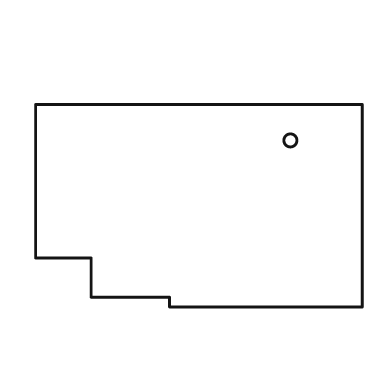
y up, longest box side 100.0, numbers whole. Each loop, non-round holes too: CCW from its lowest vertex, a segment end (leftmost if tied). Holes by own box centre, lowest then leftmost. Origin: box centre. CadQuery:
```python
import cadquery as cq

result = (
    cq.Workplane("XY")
    .moveTo(-9.0, -31.0)
    .lineTo(50.0, -31.0)
    .lineTo(50.0, 31.0)
    .lineTo(-50.0, 31.0)
    .lineTo(-50.0, -16.0)
    .lineTo(-33.0, -16.0)
    .lineTo(-33.0, -28.0)
    .lineTo(-9.0, -28.0)
    .close()
    .moveTo(28.0, 20.0)
    .circle(2.0)
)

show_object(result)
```